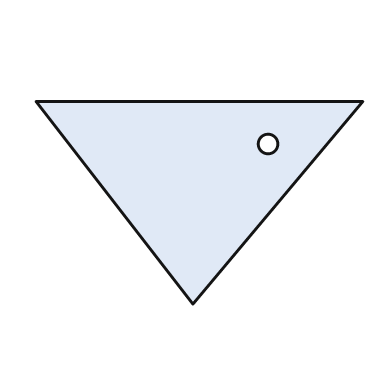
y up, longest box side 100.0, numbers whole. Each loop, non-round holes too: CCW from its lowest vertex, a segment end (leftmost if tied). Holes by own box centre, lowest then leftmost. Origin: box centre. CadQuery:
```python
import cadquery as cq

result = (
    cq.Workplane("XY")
    .moveTo(-2.0, -31.0)
    .lineTo(50.0, 31.0)
    .lineTo(-50.0, 31.0)
    .close()
    .moveTo(21.0, 18.0)
    .circle(3.0)
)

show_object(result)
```